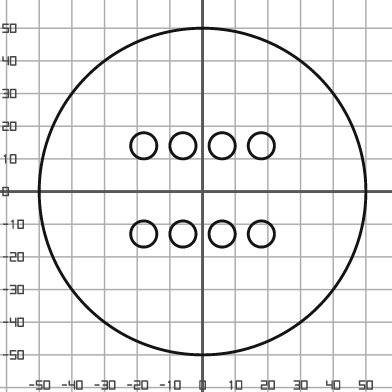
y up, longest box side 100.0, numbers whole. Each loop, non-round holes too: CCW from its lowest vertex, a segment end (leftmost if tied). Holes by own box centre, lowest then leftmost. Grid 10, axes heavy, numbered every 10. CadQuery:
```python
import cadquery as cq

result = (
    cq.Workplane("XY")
    .moveTo(0.0, 0.0)
    .circle(50.0)
    .moveTo(-18.0, -13.0)
    .circle(4.0)
    .moveTo(-6.0, -13.0)
    .circle(4.0)
    .moveTo(6.0, -13.0)
    .circle(4.0)
    .moveTo(18.0, -13.0)
    .circle(4.0)
    .moveTo(-18.0, 14.0)
    .circle(4.0)
    .moveTo(-6.0, 14.0)
    .circle(4.0)
    .moveTo(6.0, 14.0)
    .circle(4.0)
    .moveTo(18.0, 14.0)
    .circle(4.0)
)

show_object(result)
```